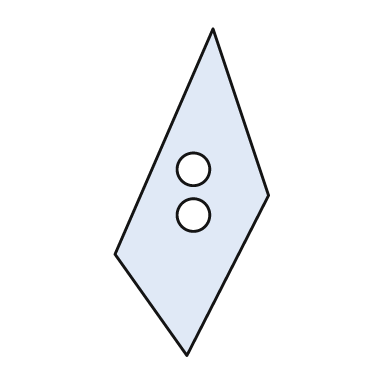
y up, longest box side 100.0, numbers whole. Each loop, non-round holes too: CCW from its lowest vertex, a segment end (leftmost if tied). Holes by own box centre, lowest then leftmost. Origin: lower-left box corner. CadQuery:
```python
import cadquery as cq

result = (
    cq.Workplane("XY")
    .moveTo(22.0, 0.0)
    .lineTo(47.0, 49.0)
    .lineTo(30.0, 100.0)
    .lineTo(0.0, 31.0)
    .close()
    .moveTo(24.0, 43.0)
    .circle(5.0)
    .moveTo(24.0, 57.0)
    .circle(5.0)
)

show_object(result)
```